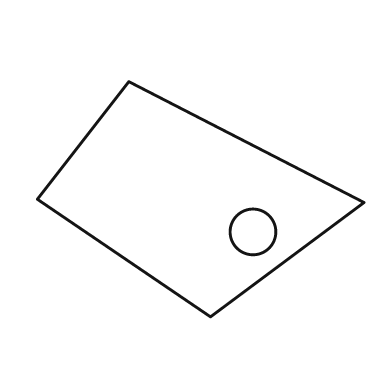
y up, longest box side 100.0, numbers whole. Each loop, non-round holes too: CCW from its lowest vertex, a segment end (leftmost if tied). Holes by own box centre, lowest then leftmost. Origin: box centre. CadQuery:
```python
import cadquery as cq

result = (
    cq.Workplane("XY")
    .moveTo(3.0, -36.0)
    .lineTo(50.0, -1.0)
    .lineTo(-22.0, 36.0)
    .lineTo(-50.0, 0.0)
    .close()
    .moveTo(16.0, -10.0)
    .circle(7.0)
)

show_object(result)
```